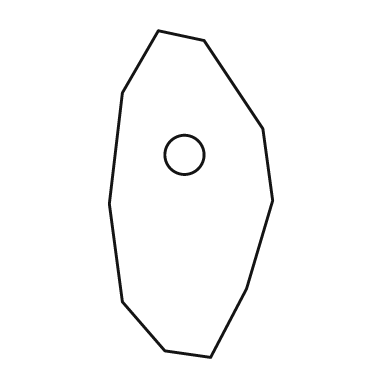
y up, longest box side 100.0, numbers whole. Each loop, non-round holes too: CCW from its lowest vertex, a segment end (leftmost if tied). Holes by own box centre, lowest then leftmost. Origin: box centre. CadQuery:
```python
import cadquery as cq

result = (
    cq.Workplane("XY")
    .moveTo(6.0, -50.0)
    .lineTo(17.0, -29.0)
    .lineTo(25.0, -2.0)
    .lineTo(22.0, 20.0)
    .lineTo(4.0, 47.0)
    .lineTo(-10.0, 50.0)
    .lineTo(-21.0, 31.0)
    .lineTo(-25.0, -3.0)
    .lineTo(-21.0, -33.0)
    .lineTo(-8.0, -48.0)
    .close()
    .moveTo(-2.0, 12.0)
    .circle(6.0)
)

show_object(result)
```